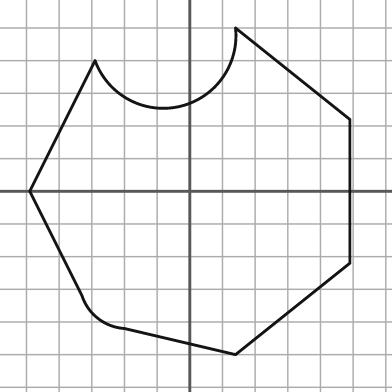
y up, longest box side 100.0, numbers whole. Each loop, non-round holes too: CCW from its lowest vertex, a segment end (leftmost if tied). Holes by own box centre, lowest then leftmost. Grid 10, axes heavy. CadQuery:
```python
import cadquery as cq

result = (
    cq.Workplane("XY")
    .moveTo(14.0, -50.0)
    .lineTo(49.0, -22.0)
    .lineTo(49.0, 22.0)
    .lineTo(14.0, 50.0)
    .threePointArc((-3.0, 26.0), (-29.0, 40.0))
    .lineTo(-49.0, 0.0)
    .lineTo(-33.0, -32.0)
    .threePointArc((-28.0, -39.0), (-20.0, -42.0))
    .close()
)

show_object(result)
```